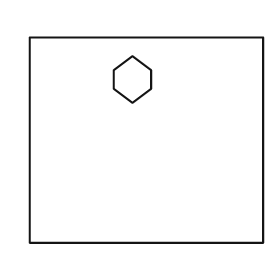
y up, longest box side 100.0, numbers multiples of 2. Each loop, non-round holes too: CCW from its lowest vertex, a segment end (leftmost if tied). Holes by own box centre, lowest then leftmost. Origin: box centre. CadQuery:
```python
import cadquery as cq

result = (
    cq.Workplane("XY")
    .moveTo(-50.0, -44.0)
    .lineTo(50.0, -44.0)
    .lineTo(50.0, 44.0)
    .lineTo(-50.0, 44.0)
    .close()
    .moveTo(-6.0, 16.0)
    .lineTo(2.0, 22.0)
    .lineTo(2.0, 30.0)
    .lineTo(-6.0, 36.0)
    .lineTo(-14.0, 30.0)
    .lineTo(-14.0, 22.0)
    .close()
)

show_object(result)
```